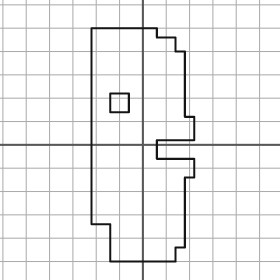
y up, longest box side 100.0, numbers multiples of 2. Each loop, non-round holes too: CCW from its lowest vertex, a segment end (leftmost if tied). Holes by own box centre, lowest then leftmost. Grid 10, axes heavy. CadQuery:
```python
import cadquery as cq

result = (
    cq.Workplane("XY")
    .moveTo(-14.0, -50.0)
    .lineTo(14.0, -50.0)
    .lineTo(14.0, -44.0)
    .lineTo(18.0, -44.0)
    .lineTo(18.0, -14.0)
    .lineTo(22.0, -14.0)
    .lineTo(22.0, -6.0)
    .lineTo(6.0, -6.0)
    .lineTo(6.0, 2.0)
    .lineTo(22.0, 2.0)
    .lineTo(22.0, 12.0)
    .lineTo(18.0, 12.0)
    .lineTo(18.0, 40.0)
    .lineTo(14.0, 40.0)
    .lineTo(14.0, 46.0)
    .lineTo(6.0, 46.0)
    .lineTo(6.0, 50.0)
    .lineTo(-22.0, 50.0)
    .lineTo(-22.0, -34.0)
    .lineTo(-14.0, -34.0)
    .close()
    .moveTo(-14.0, 14.0)
    .lineTo(-6.0, 14.0)
    .lineTo(-6.0, 22.0)
    .lineTo(-14.0, 22.0)
    .close()
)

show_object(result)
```